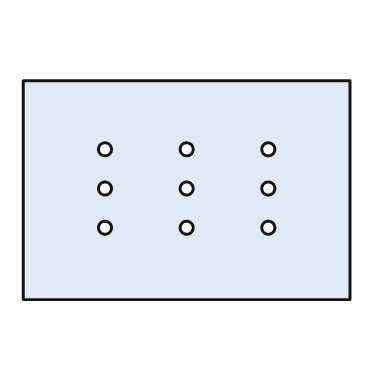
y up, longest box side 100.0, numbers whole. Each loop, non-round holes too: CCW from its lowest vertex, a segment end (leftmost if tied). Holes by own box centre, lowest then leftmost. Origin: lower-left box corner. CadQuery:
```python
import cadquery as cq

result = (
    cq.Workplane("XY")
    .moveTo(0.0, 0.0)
    .lineTo(100.0, 0.0)
    .lineTo(100.0, 67.0)
    .lineTo(0.0, 67.0)
    .close()
    .moveTo(25.0, 22.0)
    .circle(2.0)
    .moveTo(50.0, 22.0)
    .circle(2.0)
    .moveTo(75.0, 22.0)
    .circle(2.0)
    .moveTo(25.0, 34.0)
    .circle(2.0)
    .moveTo(50.0, 34.0)
    .circle(2.0)
    .moveTo(75.0, 34.0)
    .circle(2.0)
    .moveTo(25.0, 46.0)
    .circle(2.0)
    .moveTo(50.0, 46.0)
    .circle(2.0)
    .moveTo(75.0, 46.0)
    .circle(2.0)
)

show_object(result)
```